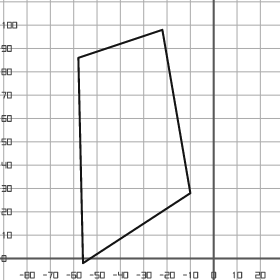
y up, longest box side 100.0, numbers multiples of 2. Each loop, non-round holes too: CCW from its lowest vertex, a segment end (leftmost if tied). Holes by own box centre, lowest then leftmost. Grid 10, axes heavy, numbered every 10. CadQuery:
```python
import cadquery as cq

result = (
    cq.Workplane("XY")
    .moveTo(-56.0, -2.0)
    .lineTo(-10.0, 28.0)
    .lineTo(-22.0, 98.0)
    .lineTo(-58.0, 86.0)
    .close()
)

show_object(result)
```